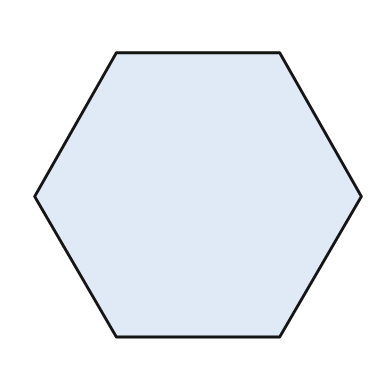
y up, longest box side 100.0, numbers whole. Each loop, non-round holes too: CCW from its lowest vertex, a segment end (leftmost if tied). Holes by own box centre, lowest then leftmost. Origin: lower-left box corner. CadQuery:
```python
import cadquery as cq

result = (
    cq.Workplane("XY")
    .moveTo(25.0, 0.0)
    .lineTo(75.0, 0.0)
    .lineTo(100.0, 43.0)
    .lineTo(75.0, 87.0)
    .lineTo(25.0, 87.0)
    .lineTo(0.0, 43.0)
    .close()
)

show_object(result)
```